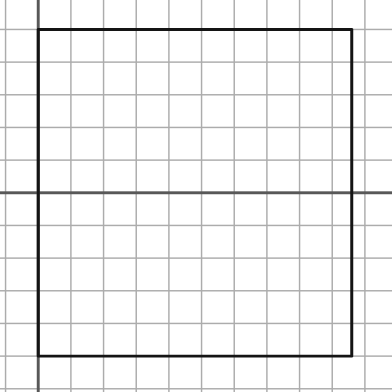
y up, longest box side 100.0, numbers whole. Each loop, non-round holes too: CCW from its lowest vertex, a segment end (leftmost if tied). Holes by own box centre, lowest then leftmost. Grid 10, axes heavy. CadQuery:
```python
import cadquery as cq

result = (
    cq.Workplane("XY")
    .moveTo(0.0, -50.0)
    .lineTo(96.0, -50.0)
    .lineTo(96.0, 50.0)
    .lineTo(0.0, 50.0)
    .close()
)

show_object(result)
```